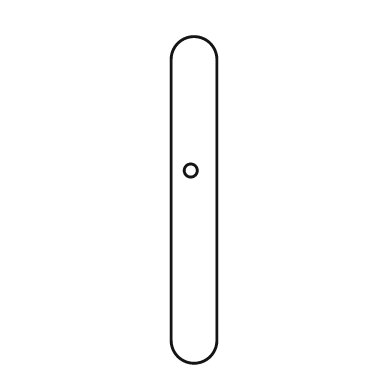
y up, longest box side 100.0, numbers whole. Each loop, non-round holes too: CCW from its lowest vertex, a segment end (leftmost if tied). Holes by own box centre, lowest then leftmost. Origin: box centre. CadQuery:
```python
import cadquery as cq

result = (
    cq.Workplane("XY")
    .moveTo(-7.0, -43.0)
    .threePointArc((0.0, -50.0), (7.0, -43.0))
    .lineTo(7.0, 43.0)
    .threePointArc((0.0, 50.0), (-7.0, 43.0))
    .close()
    .moveTo(-1.0, 9.0)
    .circle(2.0)
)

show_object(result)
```